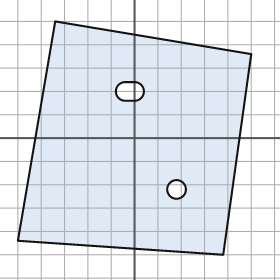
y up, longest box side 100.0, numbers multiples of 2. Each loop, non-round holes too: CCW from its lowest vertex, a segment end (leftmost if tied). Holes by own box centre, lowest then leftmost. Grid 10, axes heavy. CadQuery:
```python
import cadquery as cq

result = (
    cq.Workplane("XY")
    .moveTo(38.0, -50.0)
    .lineTo(50.0, 36.0)
    .lineTo(-34.0, 50.0)
    .lineTo(-50.0, -44.0)
    .close()
    .moveTo(18.0, -22.0)
    .circle(4.0)
    .moveTo(-4.0, 16.0)
    .lineTo(0.0, 16.0)
    .threePointArc((4.0, 20.0), (0.0, 24.0))
    .lineTo(-4.0, 24.0)
    .threePointArc((-8.0, 20.0), (-4.0, 16.0))
    .close()
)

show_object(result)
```